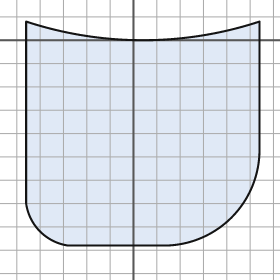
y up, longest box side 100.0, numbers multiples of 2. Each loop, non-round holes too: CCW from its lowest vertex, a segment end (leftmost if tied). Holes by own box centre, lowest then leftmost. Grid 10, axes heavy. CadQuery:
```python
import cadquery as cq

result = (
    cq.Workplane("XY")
    .moveTo(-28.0, -88.0)
    .lineTo(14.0, -88.0)
    .threePointArc((42.0, -76.0), (54.0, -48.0))
    .lineTo(54.0, 8.0)
    .threePointArc((4.0, 0.0), (-46.0, 8.0))
    .lineTo(-46.0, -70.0)
    .threePointArc((-40.0, -82.0), (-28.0, -88.0))
    .close()
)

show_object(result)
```